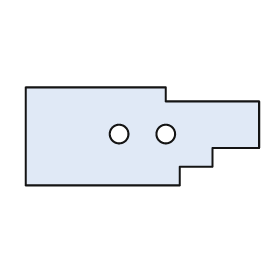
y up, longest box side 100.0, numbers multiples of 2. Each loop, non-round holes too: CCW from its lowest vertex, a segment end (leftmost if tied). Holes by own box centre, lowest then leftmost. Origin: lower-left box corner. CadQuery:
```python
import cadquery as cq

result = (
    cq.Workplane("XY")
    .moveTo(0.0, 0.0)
    .lineTo(66.0, 0.0)
    .lineTo(66.0, 8.0)
    .lineTo(80.0, 8.0)
    .lineTo(80.0, 16.0)
    .lineTo(100.0, 16.0)
    .lineTo(100.0, 36.0)
    .lineTo(60.0, 36.0)
    .lineTo(60.0, 42.0)
    .lineTo(0.0, 42.0)
    .close()
    .moveTo(40.0, 22.0)
    .circle(4.0)
    .moveTo(60.0, 22.0)
    .circle(4.0)
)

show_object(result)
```